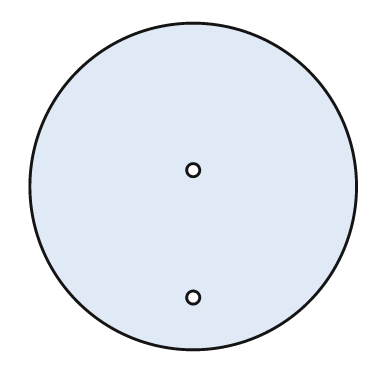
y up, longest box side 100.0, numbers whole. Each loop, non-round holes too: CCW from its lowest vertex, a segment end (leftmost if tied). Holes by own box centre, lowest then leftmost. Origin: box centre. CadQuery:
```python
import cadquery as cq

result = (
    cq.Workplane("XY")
    .moveTo(0.0, 0.0)
    .circle(50.0)
    .moveTo(0.0, -34.0)
    .circle(2.0)
    .moveTo(0.0, 5.0)
    .circle(2.0)
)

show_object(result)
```